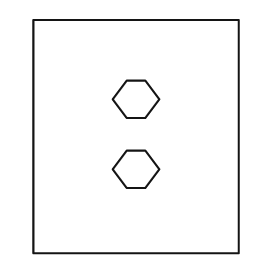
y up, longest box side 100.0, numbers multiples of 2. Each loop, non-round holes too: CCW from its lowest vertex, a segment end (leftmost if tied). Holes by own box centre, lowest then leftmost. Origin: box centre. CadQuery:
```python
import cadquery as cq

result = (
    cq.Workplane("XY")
    .moveTo(-44.0, -50.0)
    .lineTo(44.0, -50.0)
    .lineTo(44.0, 50.0)
    .lineTo(-44.0, 50.0)
    .close()
    .moveTo(-4.0, -22.0)
    .lineTo(4.0, -22.0)
    .lineTo(10.0, -14.0)
    .lineTo(4.0, -6.0)
    .lineTo(-4.0, -6.0)
    .lineTo(-10.0, -14.0)
    .close()
    .moveTo(-4.0, 8.0)
    .lineTo(4.0, 8.0)
    .lineTo(10.0, 16.0)
    .lineTo(4.0, 24.0)
    .lineTo(-4.0, 24.0)
    .lineTo(-10.0, 16.0)
    .close()
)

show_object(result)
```